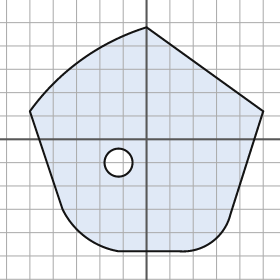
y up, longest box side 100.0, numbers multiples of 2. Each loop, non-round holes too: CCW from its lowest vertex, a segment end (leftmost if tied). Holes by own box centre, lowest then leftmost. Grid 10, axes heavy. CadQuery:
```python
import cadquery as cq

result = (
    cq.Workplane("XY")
    .moveTo(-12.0, -48.0)
    .lineTo(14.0, -48.0)
    .threePointArc((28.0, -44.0), (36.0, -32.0))
    .lineTo(50.0, 12.0)
    .lineTo(0.0, 48.0)
    .threePointArc((-28.0, 34.0), (-50.0, 12.0))
    .lineTo(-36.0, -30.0)
    .threePointArc((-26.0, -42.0), (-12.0, -48.0))
    .close()
    .moveTo(-12.0, -10.0)
    .circle(6.0)
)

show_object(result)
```